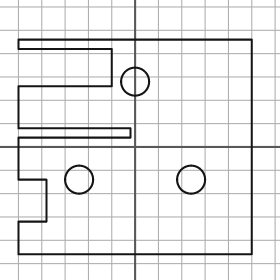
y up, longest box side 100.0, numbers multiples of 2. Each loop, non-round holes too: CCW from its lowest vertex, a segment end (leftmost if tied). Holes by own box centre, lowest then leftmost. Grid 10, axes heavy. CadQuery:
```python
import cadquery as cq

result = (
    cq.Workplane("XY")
    .moveTo(-50.0, -46.0)
    .lineTo(50.0, -46.0)
    .lineTo(50.0, 46.0)
    .lineTo(-50.0, 46.0)
    .lineTo(-50.0, 42.0)
    .lineTo(-10.0, 42.0)
    .lineTo(-10.0, 26.0)
    .lineTo(-50.0, 26.0)
    .lineTo(-50.0, 8.0)
    .lineTo(-2.0, 8.0)
    .lineTo(-2.0, 4.0)
    .lineTo(-50.0, 4.0)
    .lineTo(-50.0, -14.0)
    .lineTo(-38.0, -14.0)
    .lineTo(-38.0, -32.0)
    .lineTo(-50.0, -32.0)
    .close()
    .moveTo(-24.0, -14.0)
    .circle(6.0)
    .moveTo(24.0, -14.0)
    .circle(6.0)
    .moveTo(0.0, 28.0)
    .circle(6.0)
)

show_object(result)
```